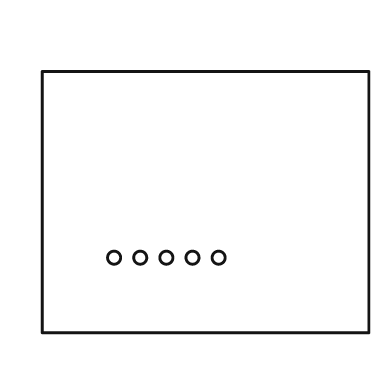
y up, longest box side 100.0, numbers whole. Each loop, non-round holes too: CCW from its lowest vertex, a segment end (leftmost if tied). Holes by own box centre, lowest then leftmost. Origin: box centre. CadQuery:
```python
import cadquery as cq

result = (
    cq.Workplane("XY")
    .moveTo(-50.0, -40.0)
    .lineTo(50.0, -40.0)
    .lineTo(50.0, 40.0)
    .lineTo(-50.0, 40.0)
    .close()
    .moveTo(-28.0, -17.0)
    .circle(2.0)
    .moveTo(-20.0, -17.0)
    .circle(2.0)
    .moveTo(-12.0, -17.0)
    .circle(2.0)
    .moveTo(-4.0, -17.0)
    .circle(2.0)
    .moveTo(4.0, -17.0)
    .circle(2.0)
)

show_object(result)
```